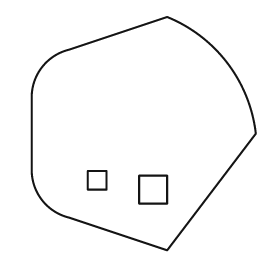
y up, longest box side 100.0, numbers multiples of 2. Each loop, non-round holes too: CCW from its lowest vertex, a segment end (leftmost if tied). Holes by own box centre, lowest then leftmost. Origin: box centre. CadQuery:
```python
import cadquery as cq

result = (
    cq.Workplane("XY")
    .moveTo(10.0, -50.0)
    .lineTo(48.0, 0.0)
    .threePointArc((36.0, 30.0), (10.0, 50.0))
    .lineTo(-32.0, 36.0)
    .threePointArc((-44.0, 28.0), (-48.0, 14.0))
    .lineTo(-48.0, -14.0)
    .threePointArc((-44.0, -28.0), (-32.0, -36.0))
    .close()
    .moveTo(-2.0, -30.0)
    .lineTo(10.0, -30.0)
    .lineTo(10.0, -18.0)
    .lineTo(-2.0, -18.0)
    .close()
    .moveTo(-24.0, -24.0)
    .lineTo(-16.0, -24.0)
    .lineTo(-16.0, -16.0)
    .lineTo(-24.0, -16.0)
    .close()
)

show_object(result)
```